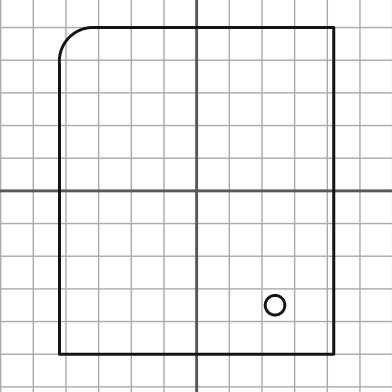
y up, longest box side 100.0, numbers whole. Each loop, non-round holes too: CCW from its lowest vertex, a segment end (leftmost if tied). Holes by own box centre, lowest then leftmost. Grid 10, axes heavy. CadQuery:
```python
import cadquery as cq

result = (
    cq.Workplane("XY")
    .moveTo(-42.0, -50.0)
    .lineTo(42.0, -50.0)
    .lineTo(42.0, 50.0)
    .lineTo(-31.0, 50.0)
    .threePointArc((-39.0, 47.0), (-42.0, 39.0))
    .close()
    .moveTo(24.0, -35.0)
    .circle(3.0)
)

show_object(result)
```